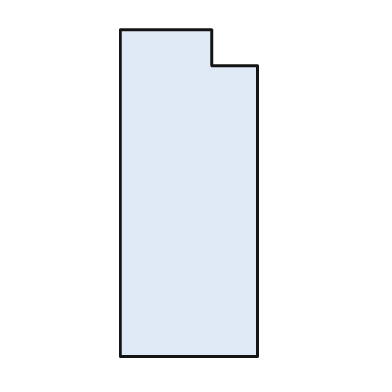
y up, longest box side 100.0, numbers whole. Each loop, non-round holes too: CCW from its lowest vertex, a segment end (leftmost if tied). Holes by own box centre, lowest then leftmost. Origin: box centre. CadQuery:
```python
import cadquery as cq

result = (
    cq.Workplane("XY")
    .moveTo(-21.0, -50.0)
    .lineTo(21.0, -50.0)
    .lineTo(21.0, 39.0)
    .lineTo(7.0, 39.0)
    .lineTo(7.0, 50.0)
    .lineTo(-21.0, 50.0)
    .close()
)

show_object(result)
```